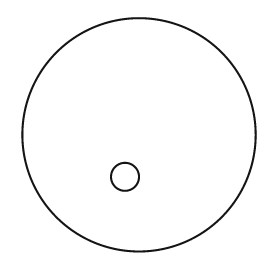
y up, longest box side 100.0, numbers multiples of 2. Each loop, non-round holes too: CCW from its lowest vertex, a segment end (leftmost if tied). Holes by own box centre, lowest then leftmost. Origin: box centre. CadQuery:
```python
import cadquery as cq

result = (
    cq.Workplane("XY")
    .moveTo(0.0, 0.0)
    .circle(50.0)
    .moveTo(-6.0, -18.0)
    .circle(6.0)
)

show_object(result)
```